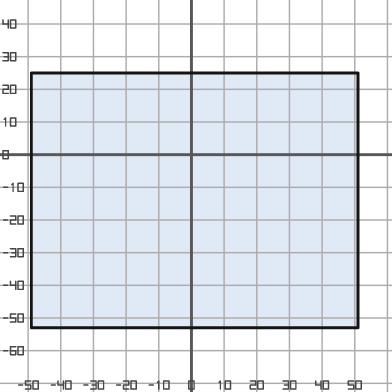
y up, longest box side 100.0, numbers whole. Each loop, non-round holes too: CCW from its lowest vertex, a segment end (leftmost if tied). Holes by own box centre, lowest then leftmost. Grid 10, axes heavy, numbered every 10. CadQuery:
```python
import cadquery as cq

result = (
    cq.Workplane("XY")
    .moveTo(-49.0, -53.0)
    .lineTo(51.0, -53.0)
    .lineTo(51.0, 25.0)
    .lineTo(-49.0, 25.0)
    .close()
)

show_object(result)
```